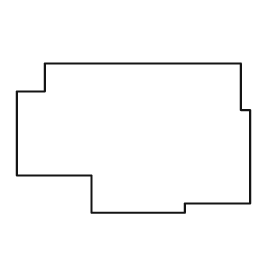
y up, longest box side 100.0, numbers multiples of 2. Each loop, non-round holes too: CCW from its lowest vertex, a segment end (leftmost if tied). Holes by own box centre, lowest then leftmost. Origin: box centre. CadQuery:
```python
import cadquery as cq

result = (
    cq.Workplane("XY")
    .moveTo(-18.0, -32.0)
    .lineTo(22.0, -32.0)
    .lineTo(22.0, -28.0)
    .lineTo(50.0, -28.0)
    .lineTo(50.0, 12.0)
    .lineTo(46.0, 12.0)
    .lineTo(46.0, 32.0)
    .lineTo(-38.0, 32.0)
    .lineTo(-38.0, 20.0)
    .lineTo(-50.0, 20.0)
    .lineTo(-50.0, -16.0)
    .lineTo(-18.0, -16.0)
    .close()
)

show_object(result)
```